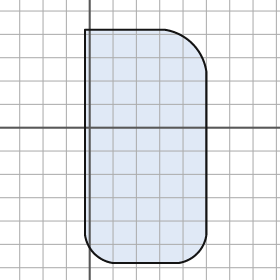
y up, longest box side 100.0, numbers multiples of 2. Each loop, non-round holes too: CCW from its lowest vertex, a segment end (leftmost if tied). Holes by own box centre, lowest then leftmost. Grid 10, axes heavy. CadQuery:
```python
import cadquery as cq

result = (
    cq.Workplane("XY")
    .moveTo(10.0, -58.0)
    .lineTo(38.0, -58.0)
    .threePointArc((46.0, -54.0), (50.0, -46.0))
    .lineTo(50.0, 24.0)
    .threePointArc((44.0, 36.0), (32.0, 42.0))
    .lineTo(-2.0, 42.0)
    .lineTo(-2.0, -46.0)
    .threePointArc((2.0, -54.0), (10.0, -58.0))
    .close()
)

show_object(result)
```